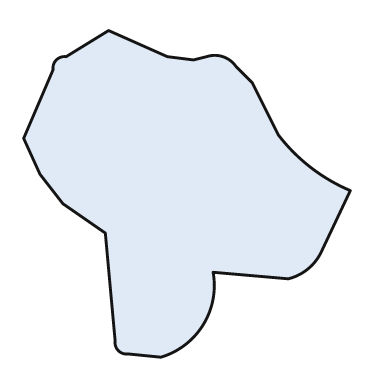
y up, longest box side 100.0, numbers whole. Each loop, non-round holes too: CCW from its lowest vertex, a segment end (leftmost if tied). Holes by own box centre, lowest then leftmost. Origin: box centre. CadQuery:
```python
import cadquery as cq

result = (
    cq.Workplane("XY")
    .moveTo(-8.0, -50.0)
    .threePointArc((5.0, -40.0), (8.0, -24.0))
    .lineTo(31.0, -26.0)
    .threePointArc((37.0, -23.0), (41.0, -18.0))
    .lineTo(50.0, 1.0)
    .threePointArc((38.0, 8.0), (28.0, 18.0))
    .lineTo(20.0, 34.0)
    .lineTo(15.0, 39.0)
    .threePointArc((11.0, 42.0), (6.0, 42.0))
    .lineTo(2.0, 41.0)
    .lineTo(-6.0, 42.0)
    .lineTo(-24.0, 50.0)
    .lineTo(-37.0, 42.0)
    .threePointArc((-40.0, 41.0), (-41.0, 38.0))
    .lineTo(-50.0, 17.0)
    .lineTo(-45.0, 6.0)
    .lineTo(-38.0, -3.0)
    .lineTo(-25.0, -12.0)
    .lineTo(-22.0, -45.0)
    .threePointArc((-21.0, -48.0), (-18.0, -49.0))
    .close()
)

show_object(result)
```